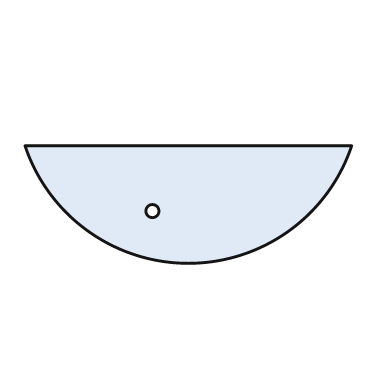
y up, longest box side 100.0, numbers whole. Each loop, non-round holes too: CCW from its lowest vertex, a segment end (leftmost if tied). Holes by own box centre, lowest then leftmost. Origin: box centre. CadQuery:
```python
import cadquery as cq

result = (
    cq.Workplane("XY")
    .moveTo(-50.0, 18.0)
    .threePointArc((0.0, -18.0), (50.0, 18.0))
    .close()
    .moveTo(-11.0, -2.0)
    .circle(2.0)
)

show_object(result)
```